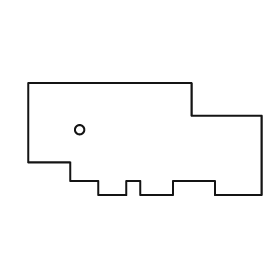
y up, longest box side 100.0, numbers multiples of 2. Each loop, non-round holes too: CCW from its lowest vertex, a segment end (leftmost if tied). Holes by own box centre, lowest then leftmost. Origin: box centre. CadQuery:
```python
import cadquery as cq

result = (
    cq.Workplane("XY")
    .moveTo(-20.0, -24.0)
    .lineTo(-8.0, -24.0)
    .lineTo(-8.0, -18.0)
    .lineTo(-2.0, -18.0)
    .lineTo(-2.0, -24.0)
    .lineTo(12.0, -24.0)
    .lineTo(12.0, -18.0)
    .lineTo(30.0, -18.0)
    .lineTo(30.0, -24.0)
    .lineTo(50.0, -24.0)
    .lineTo(50.0, 10.0)
    .lineTo(20.0, 10.0)
    .lineTo(20.0, 24.0)
    .lineTo(-50.0, 24.0)
    .lineTo(-50.0, -10.0)
    .lineTo(-32.0, -10.0)
    .lineTo(-32.0, -18.0)
    .lineTo(-20.0, -18.0)
    .close()
    .moveTo(-28.0, 4.0)
    .circle(2.0)
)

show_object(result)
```